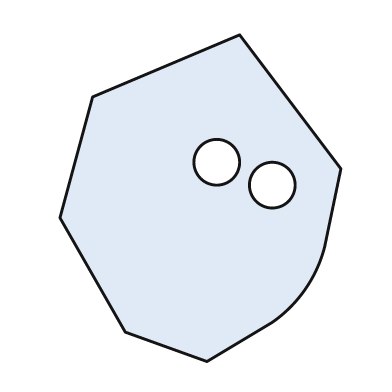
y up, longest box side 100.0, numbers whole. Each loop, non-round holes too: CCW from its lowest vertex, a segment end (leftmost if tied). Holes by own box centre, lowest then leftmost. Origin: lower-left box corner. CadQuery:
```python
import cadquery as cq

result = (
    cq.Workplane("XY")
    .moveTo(45.0, 0.0)
    .lineTo(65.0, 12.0)
    .threePointArc((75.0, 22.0), (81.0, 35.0))
    .lineTo(86.0, 59.0)
    .lineTo(55.0, 100.0)
    .lineTo(10.0, 81.0)
    .lineTo(0.0, 44.0)
    .lineTo(20.0, 9.0)
    .close()
    .moveTo(65.0, 54.0)
    .circle(7.0)
    .moveTo(48.0, 61.0)
    .circle(7.0)
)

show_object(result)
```